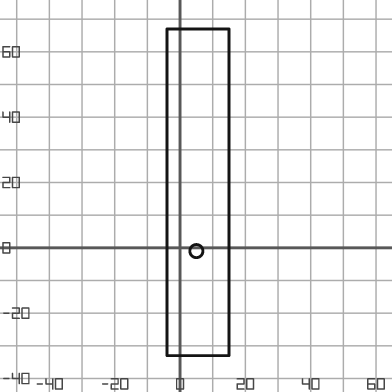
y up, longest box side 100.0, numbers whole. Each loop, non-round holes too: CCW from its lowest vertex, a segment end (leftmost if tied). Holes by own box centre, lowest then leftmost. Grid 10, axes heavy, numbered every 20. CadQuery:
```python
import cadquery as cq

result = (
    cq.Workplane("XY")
    .moveTo(-4.0, -33.0)
    .lineTo(15.0, -33.0)
    .lineTo(15.0, 67.0)
    .lineTo(-4.0, 67.0)
    .close()
    .moveTo(5.0, -1.0)
    .circle(2.0)
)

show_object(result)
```